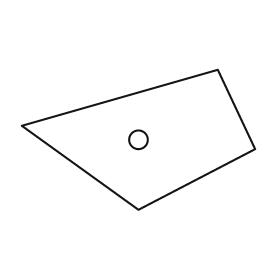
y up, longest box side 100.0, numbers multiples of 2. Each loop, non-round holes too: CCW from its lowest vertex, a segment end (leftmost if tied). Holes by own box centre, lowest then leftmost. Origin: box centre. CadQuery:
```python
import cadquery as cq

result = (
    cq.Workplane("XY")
    .moveTo(0.0, -30.0)
    .lineTo(50.0, -4.0)
    .lineTo(34.0, 30.0)
    .lineTo(-50.0, 6.0)
    .close()
    .moveTo(0.0, 0.0)
    .circle(4.0)
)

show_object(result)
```